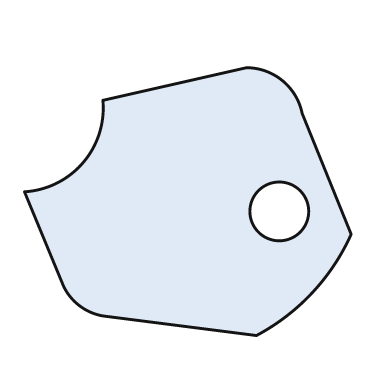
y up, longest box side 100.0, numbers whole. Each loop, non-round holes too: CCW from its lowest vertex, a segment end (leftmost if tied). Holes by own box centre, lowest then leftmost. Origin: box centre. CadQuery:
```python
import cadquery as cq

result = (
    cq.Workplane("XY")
    .moveTo(21.0, -41.0)
    .threePointArc((38.0, -28.0), (50.0, -10.0))
    .lineTo(35.0, 27.0)
    .threePointArc((29.0, 37.0), (18.0, 41.0))
    .lineTo(-26.0, 31.0)
    .threePointArc((-32.0, 12.0), (-50.0, 3.0))
    .lineTo(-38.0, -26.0)
    .threePointArc((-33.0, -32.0), (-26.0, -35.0))
    .close()
    .moveTo(28.0, -3.0)
    .circle(9.0)
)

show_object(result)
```